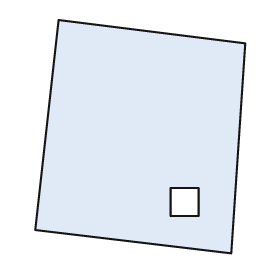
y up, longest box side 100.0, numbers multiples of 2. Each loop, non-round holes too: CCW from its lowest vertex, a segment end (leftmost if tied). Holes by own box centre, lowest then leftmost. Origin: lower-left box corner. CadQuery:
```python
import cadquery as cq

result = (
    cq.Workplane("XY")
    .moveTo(84.0, 0.0)
    .lineTo(90.0, 90.0)
    .lineTo(10.0, 100.0)
    .lineTo(0.0, 10.0)
    .close()
    .moveTo(58.0, 16.0)
    .lineTo(70.0, 16.0)
    .lineTo(70.0, 28.0)
    .lineTo(58.0, 28.0)
    .close()
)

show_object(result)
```